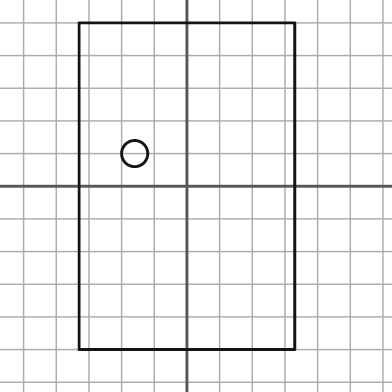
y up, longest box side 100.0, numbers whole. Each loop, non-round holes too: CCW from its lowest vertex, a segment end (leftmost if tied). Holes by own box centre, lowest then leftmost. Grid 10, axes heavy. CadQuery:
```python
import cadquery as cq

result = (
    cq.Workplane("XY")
    .moveTo(-33.0, -50.0)
    .lineTo(33.0, -50.0)
    .lineTo(33.0, 50.0)
    .lineTo(-33.0, 50.0)
    .close()
    .moveTo(-16.0, 10.0)
    .circle(4.0)
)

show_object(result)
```